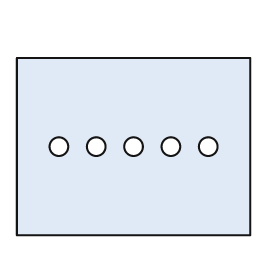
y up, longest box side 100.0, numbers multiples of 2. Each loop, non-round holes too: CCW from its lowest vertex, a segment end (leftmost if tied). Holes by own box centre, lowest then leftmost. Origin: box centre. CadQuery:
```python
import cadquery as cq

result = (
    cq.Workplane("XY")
    .moveTo(-50.0, -38.0)
    .lineTo(50.0, -38.0)
    .lineTo(50.0, 38.0)
    .lineTo(-50.0, 38.0)
    .close()
    .moveTo(-32.0, 0.0)
    .circle(4.0)
    .moveTo(-16.0, 0.0)
    .circle(4.0)
    .moveTo(0.0, 0.0)
    .circle(4.0)
    .moveTo(16.0, 0.0)
    .circle(4.0)
    .moveTo(32.0, 0.0)
    .circle(4.0)
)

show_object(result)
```